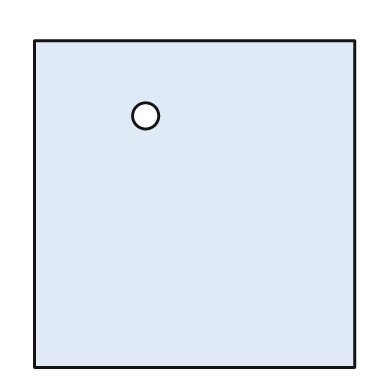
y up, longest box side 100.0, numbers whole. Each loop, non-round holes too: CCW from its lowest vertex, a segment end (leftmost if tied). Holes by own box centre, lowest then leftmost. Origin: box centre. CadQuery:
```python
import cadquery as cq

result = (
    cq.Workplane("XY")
    .moveTo(-49.0, -50.0)
    .lineTo(49.0, -50.0)
    .lineTo(49.0, 50.0)
    .lineTo(-49.0, 50.0)
    .close()
    .moveTo(-15.0, 27.0)
    .circle(4.0)
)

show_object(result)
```